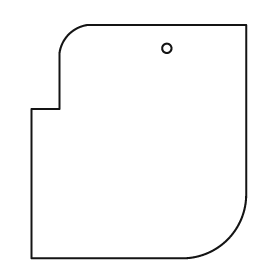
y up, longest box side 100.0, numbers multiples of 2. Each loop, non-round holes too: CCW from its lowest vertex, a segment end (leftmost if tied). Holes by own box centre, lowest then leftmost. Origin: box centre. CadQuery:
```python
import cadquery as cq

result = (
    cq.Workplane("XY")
    .moveTo(-46.0, -50.0)
    .lineTo(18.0, -50.0)
    .threePointArc((38.0, -42.0), (46.0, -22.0))
    .lineTo(46.0, 50.0)
    .lineTo(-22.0, 50.0)
    .threePointArc((-30.0, 46.0), (-34.0, 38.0))
    .lineTo(-34.0, 14.0)
    .lineTo(-46.0, 14.0)
    .close()
    .moveTo(12.0, 40.0)
    .circle(2.0)
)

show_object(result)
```